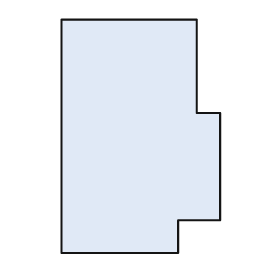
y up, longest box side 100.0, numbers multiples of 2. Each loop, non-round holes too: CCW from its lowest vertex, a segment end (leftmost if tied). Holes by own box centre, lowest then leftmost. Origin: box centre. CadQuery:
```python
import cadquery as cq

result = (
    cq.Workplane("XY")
    .moveTo(-34.0, -50.0)
    .lineTo(16.0, -50.0)
    .lineTo(16.0, -36.0)
    .lineTo(34.0, -36.0)
    .lineTo(34.0, 10.0)
    .lineTo(24.0, 10.0)
    .lineTo(24.0, 50.0)
    .lineTo(-34.0, 50.0)
    .close()
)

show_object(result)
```